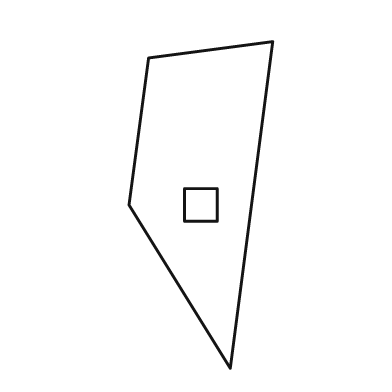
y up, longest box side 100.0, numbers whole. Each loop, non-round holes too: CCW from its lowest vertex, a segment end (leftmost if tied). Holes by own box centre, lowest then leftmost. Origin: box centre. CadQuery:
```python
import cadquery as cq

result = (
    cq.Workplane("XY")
    .moveTo(9.0, -50.0)
    .lineTo(22.0, 50.0)
    .lineTo(-16.0, 45.0)
    .lineTo(-22.0, 0.0)
    .close()
    .moveTo(-5.0, -5.0)
    .lineTo(5.0, -5.0)
    .lineTo(5.0, 5.0)
    .lineTo(-5.0, 5.0)
    .close()
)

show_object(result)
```